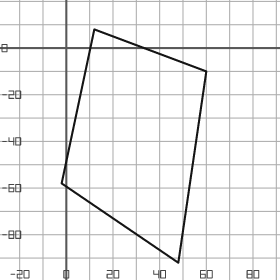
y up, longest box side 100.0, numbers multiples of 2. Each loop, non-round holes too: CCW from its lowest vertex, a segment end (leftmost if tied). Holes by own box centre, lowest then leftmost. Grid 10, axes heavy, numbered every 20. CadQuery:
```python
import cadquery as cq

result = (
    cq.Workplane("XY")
    .moveTo(48.0, -92.0)
    .lineTo(60.0, -10.0)
    .lineTo(12.0, 8.0)
    .lineTo(-2.0, -58.0)
    .close()
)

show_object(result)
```